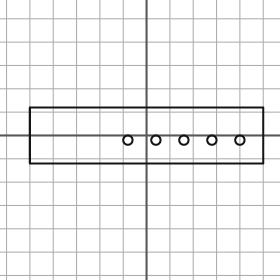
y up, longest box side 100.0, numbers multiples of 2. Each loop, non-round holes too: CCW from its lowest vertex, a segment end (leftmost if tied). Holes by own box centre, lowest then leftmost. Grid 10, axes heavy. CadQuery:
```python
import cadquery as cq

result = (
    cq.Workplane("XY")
    .moveTo(-50.0, -12.0)
    .lineTo(50.0, -12.0)
    .lineTo(50.0, 12.0)
    .lineTo(-50.0, 12.0)
    .close()
    .moveTo(-8.0, -2.0)
    .circle(2.0)
    .moveTo(4.0, -2.0)
    .circle(2.0)
    .moveTo(16.0, -2.0)
    .circle(2.0)
    .moveTo(28.0, -2.0)
    .circle(2.0)
    .moveTo(40.0, -2.0)
    .circle(2.0)
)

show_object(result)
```